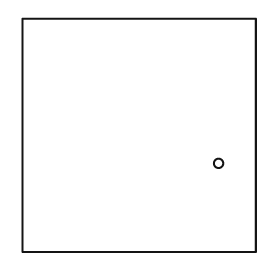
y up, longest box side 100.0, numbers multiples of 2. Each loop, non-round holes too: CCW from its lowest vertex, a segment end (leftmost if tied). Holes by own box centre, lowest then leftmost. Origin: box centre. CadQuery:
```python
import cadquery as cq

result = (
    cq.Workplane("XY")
    .moveTo(-50.0, -50.0)
    .lineTo(50.0, -50.0)
    .lineTo(50.0, 50.0)
    .lineTo(-50.0, 50.0)
    .close()
    .moveTo(34.0, -12.0)
    .circle(2.0)
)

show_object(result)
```